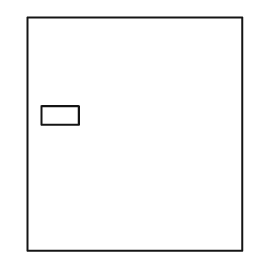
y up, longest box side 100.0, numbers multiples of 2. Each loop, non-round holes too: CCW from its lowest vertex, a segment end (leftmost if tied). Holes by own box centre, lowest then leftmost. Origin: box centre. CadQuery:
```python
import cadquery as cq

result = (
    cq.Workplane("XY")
    .moveTo(-46.0, -50.0)
    .lineTo(46.0, -50.0)
    .lineTo(46.0, 50.0)
    .lineTo(-46.0, 50.0)
    .close()
    .moveTo(-40.0, 4.0)
    .lineTo(-24.0, 4.0)
    .lineTo(-24.0, 12.0)
    .lineTo(-40.0, 12.0)
    .close()
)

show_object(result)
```